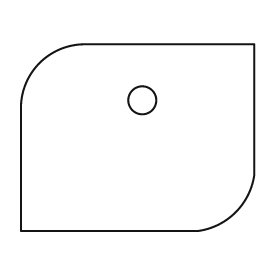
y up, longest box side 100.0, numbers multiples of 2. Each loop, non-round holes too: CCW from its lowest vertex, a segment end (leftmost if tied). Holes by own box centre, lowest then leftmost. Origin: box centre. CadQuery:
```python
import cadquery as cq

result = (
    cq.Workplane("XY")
    .moveTo(-50.0, -40.0)
    .lineTo(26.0, -40.0)
    .threePointArc((42.0, -32.0), (50.0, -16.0))
    .lineTo(50.0, 40.0)
    .lineTo(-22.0, 40.0)
    .threePointArc((-42.0, 32.0), (-50.0, 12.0))
    .close()
    .moveTo(2.0, 16.0)
    .circle(6.0)
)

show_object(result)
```